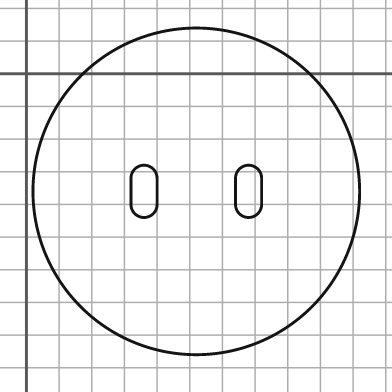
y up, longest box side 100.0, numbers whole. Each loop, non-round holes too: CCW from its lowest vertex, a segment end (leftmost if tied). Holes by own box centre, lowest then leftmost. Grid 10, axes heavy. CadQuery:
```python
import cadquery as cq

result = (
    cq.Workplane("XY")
    .moveTo(52.0, -36.0)
    .circle(50.0)
    .moveTo(32.0, -40.0)
    .threePointArc((36.0, -44.0), (40.0, -40.0))
    .lineTo(40.0, -32.0)
    .threePointArc((36.0, -28.0), (32.0, -32.0))
    .close()
    .moveTo(64.0, -40.0)
    .threePointArc((68.0, -44.0), (72.0, -40.0))
    .lineTo(72.0, -32.0)
    .threePointArc((68.0, -28.0), (64.0, -32.0))
    .close()
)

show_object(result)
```